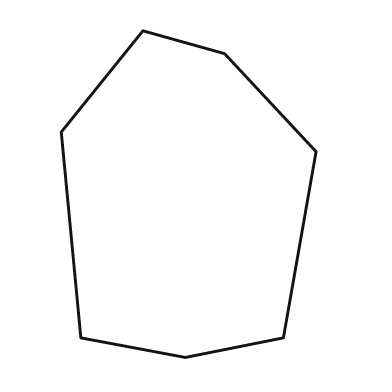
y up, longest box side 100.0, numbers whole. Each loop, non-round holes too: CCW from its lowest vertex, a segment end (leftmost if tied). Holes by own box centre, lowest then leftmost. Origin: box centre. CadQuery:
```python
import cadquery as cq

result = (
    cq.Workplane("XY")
    .moveTo(-1.0, -50.0)
    .lineTo(29.0, -44.0)
    .lineTo(39.0, 13.0)
    .lineTo(11.0, 43.0)
    .lineTo(-14.0, 50.0)
    .lineTo(-39.0, 19.0)
    .lineTo(-33.0, -44.0)
    .close()
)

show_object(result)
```